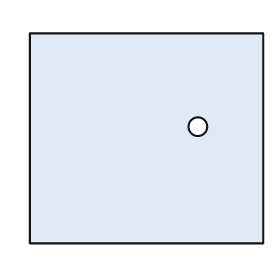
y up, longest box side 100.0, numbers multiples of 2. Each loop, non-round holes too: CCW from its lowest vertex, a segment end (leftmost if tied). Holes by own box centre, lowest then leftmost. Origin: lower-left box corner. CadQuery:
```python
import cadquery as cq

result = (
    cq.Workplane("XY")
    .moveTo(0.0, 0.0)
    .lineTo(100.0, 0.0)
    .lineTo(100.0, 90.0)
    .lineTo(0.0, 90.0)
    .close()
    .moveTo(72.0, 50.0)
    .circle(4.0)
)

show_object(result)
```